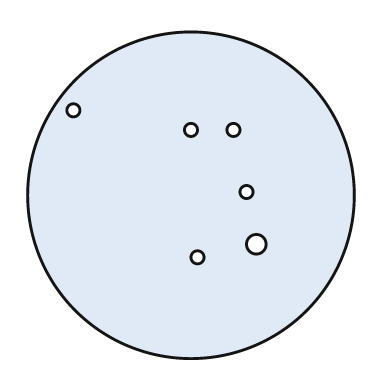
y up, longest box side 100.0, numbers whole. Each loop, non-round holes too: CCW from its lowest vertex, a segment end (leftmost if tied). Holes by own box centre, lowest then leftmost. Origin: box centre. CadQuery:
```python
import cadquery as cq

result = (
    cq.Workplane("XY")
    .moveTo(0.0, 0.0)
    .circle(50.0)
    .moveTo(2.0, -19.0)
    .circle(2.0)
    .moveTo(20.0, -15.0)
    .circle(3.0)
    .moveTo(17.0, 1.0)
    .circle(2.0)
    .moveTo(0.0, 20.0)
    .circle(2.0)
    .moveTo(13.0, 20.0)
    .circle(2.0)
    .moveTo(-36.0, 26.0)
    .circle(2.0)
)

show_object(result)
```